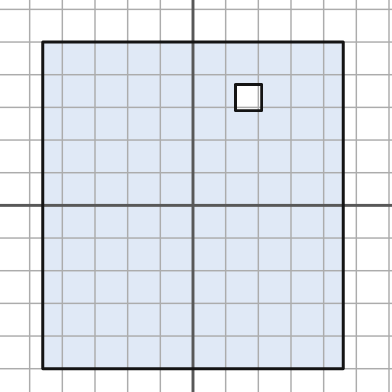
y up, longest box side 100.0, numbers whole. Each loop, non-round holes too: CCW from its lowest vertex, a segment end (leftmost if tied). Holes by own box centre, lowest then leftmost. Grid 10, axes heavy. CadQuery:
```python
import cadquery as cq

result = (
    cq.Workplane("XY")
    .moveTo(-46.0, -50.0)
    .lineTo(46.0, -50.0)
    .lineTo(46.0, 50.0)
    .lineTo(-46.0, 50.0)
    .close()
    .moveTo(13.0, 29.0)
    .lineTo(21.0, 29.0)
    .lineTo(21.0, 37.0)
    .lineTo(13.0, 37.0)
    .close()
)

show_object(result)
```